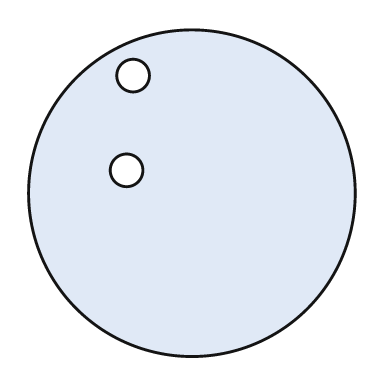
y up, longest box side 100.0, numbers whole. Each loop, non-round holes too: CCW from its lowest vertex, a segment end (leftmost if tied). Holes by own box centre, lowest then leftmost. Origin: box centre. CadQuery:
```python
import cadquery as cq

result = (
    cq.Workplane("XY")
    .moveTo(0.0, 0.0)
    .circle(50.0)
    .moveTo(-20.0, 7.0)
    .circle(5.0)
    .moveTo(-18.0, 36.0)
    .circle(5.0)
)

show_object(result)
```